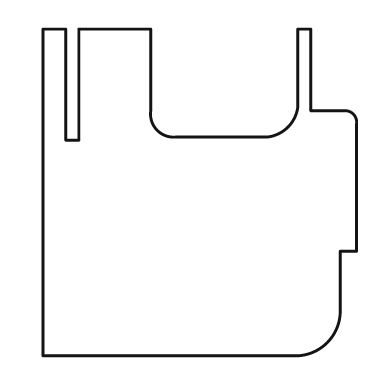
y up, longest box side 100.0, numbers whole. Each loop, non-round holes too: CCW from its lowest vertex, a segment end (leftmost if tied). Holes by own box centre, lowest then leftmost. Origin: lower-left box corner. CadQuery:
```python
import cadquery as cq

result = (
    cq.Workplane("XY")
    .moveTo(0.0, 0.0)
    .lineTo(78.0, 0.0)
    .threePointArc((87.0, 4.0), (91.0, 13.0))
    .lineTo(91.0, 32.0)
    .lineTo(96.0, 32.0)
    .lineTo(96.0, 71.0)
    .threePointArc((95.0, 74.0), (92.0, 75.0))
    .lineTo(82.0, 75.0)
    .lineTo(82.0, 100.0)
    .lineTo(78.0, 100.0)
    .lineTo(78.0, 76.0)
    .threePointArc((75.0, 70.0), (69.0, 67.0))
    .lineTo(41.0, 67.0)
    .threePointArc((35.0, 69.0), (33.0, 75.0))
    .lineTo(33.0, 100.0)
    .lineTo(11.0, 100.0)
    .lineTo(11.0, 66.0)
    .lineTo(7.0, 66.0)
    .lineTo(7.0, 100.0)
    .lineTo(0.0, 100.0)
    .close()
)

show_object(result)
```